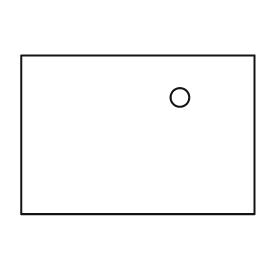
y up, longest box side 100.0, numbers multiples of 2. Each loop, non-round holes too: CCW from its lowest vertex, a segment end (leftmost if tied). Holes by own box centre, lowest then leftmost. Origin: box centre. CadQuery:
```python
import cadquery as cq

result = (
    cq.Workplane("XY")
    .moveTo(-50.0, -34.0)
    .lineTo(50.0, -34.0)
    .lineTo(50.0, 34.0)
    .lineTo(-50.0, 34.0)
    .close()
    .moveTo(18.0, 16.0)
    .circle(4.0)
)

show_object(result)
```